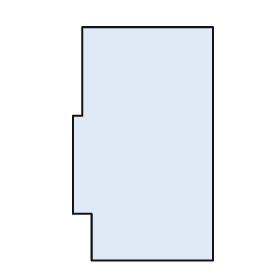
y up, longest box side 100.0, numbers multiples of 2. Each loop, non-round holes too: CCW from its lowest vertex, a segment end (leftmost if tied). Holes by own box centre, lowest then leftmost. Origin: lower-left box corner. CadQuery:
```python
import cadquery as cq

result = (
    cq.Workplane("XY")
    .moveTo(8.0, 0.0)
    .lineTo(60.0, 0.0)
    .lineTo(60.0, 100.0)
    .lineTo(4.0, 100.0)
    .lineTo(4.0, 62.0)
    .lineTo(0.0, 62.0)
    .lineTo(0.0, 20.0)
    .lineTo(8.0, 20.0)
    .close()
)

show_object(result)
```